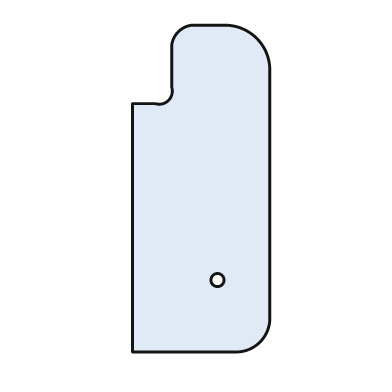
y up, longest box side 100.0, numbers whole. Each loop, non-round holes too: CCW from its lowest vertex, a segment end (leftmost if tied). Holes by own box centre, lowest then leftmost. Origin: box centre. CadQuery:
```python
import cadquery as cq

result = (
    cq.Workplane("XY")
    .moveTo(-21.0, -50.0)
    .lineTo(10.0, -50.0)
    .threePointArc((18.0, -47.0), (21.0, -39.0))
    .lineTo(21.0, 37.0)
    .threePointArc((17.0, 46.0), (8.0, 50.0))
    .lineTo(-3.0, 50.0)
    .threePointArc((-7.0, 48.0), (-9.0, 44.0))
    .lineTo(-9.0, 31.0)
    .threePointArc((-10.0, 27.0), (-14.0, 26.0))
    .lineTo(-21.0, 26.0)
    .close()
    .moveTo(5.0, -28.0)
    .circle(2.0)
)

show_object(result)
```